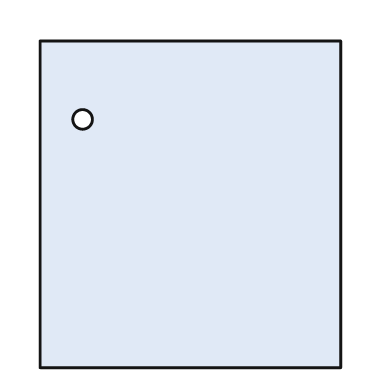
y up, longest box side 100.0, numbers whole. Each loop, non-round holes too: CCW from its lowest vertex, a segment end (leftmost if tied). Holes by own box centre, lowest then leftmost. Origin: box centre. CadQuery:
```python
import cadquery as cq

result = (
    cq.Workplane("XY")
    .moveTo(-46.0, -50.0)
    .lineTo(46.0, -50.0)
    .lineTo(46.0, 50.0)
    .lineTo(-46.0, 50.0)
    .close()
    .moveTo(-33.0, 26.0)
    .circle(3.0)
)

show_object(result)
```